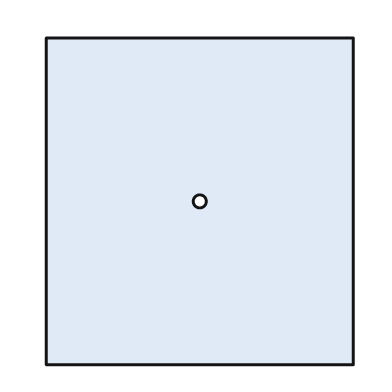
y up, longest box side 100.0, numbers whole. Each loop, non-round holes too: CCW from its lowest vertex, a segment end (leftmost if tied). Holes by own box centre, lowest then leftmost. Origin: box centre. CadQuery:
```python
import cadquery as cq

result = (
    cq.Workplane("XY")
    .moveTo(-47.0, -50.0)
    .lineTo(47.0, -50.0)
    .lineTo(47.0, 50.0)
    .lineTo(-47.0, 50.0)
    .close()
    .moveTo(0.0, 0.0)
    .circle(2.0)
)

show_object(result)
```